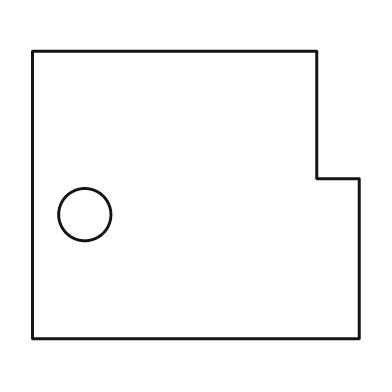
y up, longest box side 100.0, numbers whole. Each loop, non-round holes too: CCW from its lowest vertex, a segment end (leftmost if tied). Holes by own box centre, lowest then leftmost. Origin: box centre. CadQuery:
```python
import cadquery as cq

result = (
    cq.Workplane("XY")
    .moveTo(-50.0, -44.0)
    .lineTo(50.0, -44.0)
    .lineTo(50.0, 5.0)
    .lineTo(37.0, 5.0)
    .lineTo(37.0, 44.0)
    .lineTo(-50.0, 44.0)
    .close()
    .moveTo(-34.0, -6.0)
    .circle(8.0)
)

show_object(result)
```